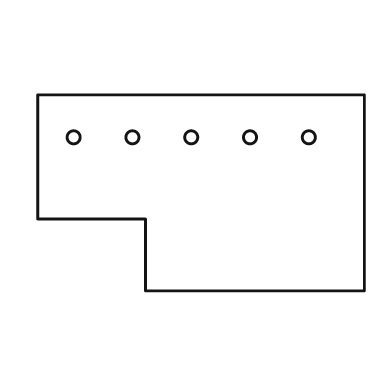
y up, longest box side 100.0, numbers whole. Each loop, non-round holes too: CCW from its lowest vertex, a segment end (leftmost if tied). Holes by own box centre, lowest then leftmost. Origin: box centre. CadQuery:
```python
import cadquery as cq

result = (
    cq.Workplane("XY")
    .moveTo(-17.0, -30.0)
    .lineTo(50.0, -30.0)
    .lineTo(50.0, 30.0)
    .lineTo(-50.0, 30.0)
    .lineTo(-50.0, -8.0)
    .lineTo(-17.0, -8.0)
    .close()
    .moveTo(-39.0, 17.0)
    .circle(2.0)
    .moveTo(-21.0, 17.0)
    .circle(2.0)
    .moveTo(-3.0, 17.0)
    .circle(2.0)
    .moveTo(15.0, 17.0)
    .circle(2.0)
    .moveTo(33.0, 17.0)
    .circle(2.0)
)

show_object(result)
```